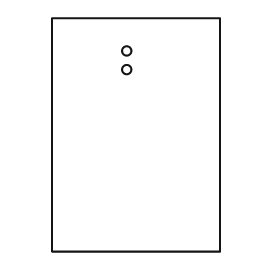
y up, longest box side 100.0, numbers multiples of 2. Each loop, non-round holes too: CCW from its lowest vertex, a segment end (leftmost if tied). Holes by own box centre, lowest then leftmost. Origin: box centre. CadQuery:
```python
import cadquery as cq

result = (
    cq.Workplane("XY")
    .moveTo(-36.0, -50.0)
    .lineTo(36.0, -50.0)
    .lineTo(36.0, 50.0)
    .lineTo(-36.0, 50.0)
    .close()
    .moveTo(-4.0, 28.0)
    .circle(2.0)
    .moveTo(-4.0, 36.0)
    .circle(2.0)
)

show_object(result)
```